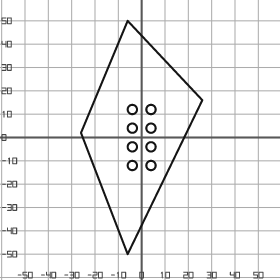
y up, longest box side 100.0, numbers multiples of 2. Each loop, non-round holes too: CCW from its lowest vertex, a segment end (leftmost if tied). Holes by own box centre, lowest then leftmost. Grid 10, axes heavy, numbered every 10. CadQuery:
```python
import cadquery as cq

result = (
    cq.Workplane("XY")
    .moveTo(-6.0, -50.0)
    .lineTo(26.0, 16.0)
    .lineTo(-6.0, 50.0)
    .lineTo(-26.0, 2.0)
    .close()
    .moveTo(-4.0, -12.0)
    .circle(2.0)
    .moveTo(4.0, -12.0)
    .circle(2.0)
    .moveTo(-4.0, -4.0)
    .circle(2.0)
    .moveTo(4.0, -4.0)
    .circle(2.0)
    .moveTo(-4.0, 4.0)
    .circle(2.0)
    .moveTo(4.0, 4.0)
    .circle(2.0)
    .moveTo(-4.0, 12.0)
    .circle(2.0)
    .moveTo(4.0, 12.0)
    .circle(2.0)
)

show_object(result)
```